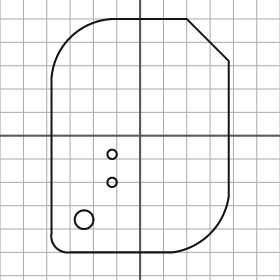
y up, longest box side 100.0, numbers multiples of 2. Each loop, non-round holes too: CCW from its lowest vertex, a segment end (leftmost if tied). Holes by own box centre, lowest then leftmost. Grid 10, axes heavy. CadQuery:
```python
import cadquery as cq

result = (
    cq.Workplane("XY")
    .moveTo(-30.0, -50.0)
    .lineTo(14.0, -50.0)
    .threePointArc((30.0, -42.0), (38.0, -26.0))
    .lineTo(38.0, 32.0)
    .lineTo(20.0, 50.0)
    .lineTo(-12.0, 50.0)
    .threePointArc((-30.0, 42.0), (-38.0, 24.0))
    .lineTo(-38.0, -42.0)
    .threePointArc((-36.0, -48.0), (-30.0, -50.0))
    .close()
    .moveTo(-24.0, -36.0)
    .circle(4.0)
    .moveTo(-12.0, -20.0)
    .circle(2.0)
    .moveTo(-12.0, -8.0)
    .circle(2.0)
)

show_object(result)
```